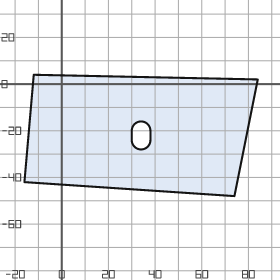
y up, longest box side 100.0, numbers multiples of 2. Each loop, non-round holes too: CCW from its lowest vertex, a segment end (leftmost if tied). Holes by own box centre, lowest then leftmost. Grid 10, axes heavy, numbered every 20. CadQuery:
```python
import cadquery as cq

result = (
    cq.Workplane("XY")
    .moveTo(74.0, -48.0)
    .lineTo(84.0, 2.0)
    .lineTo(-12.0, 4.0)
    .lineTo(-16.0, -42.0)
    .close()
    .moveTo(30.0, -24.0)
    .threePointArc((34.0, -28.0), (38.0, -24.0))
    .lineTo(38.0, -20.0)
    .threePointArc((34.0, -16.0), (30.0, -20.0))
    .close()
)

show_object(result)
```